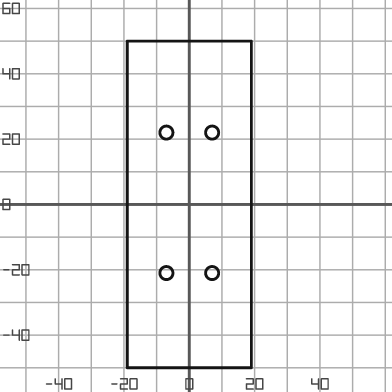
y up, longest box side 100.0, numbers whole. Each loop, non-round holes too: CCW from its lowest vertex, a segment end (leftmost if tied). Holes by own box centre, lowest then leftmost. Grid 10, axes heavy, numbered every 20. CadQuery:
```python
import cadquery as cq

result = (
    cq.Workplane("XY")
    .moveTo(-19.0, -50.0)
    .lineTo(19.0, -50.0)
    .lineTo(19.0, 50.0)
    .lineTo(-19.0, 50.0)
    .close()
    .moveTo(-7.0, -21.0)
    .circle(2.0)
    .moveTo(7.0, -21.0)
    .circle(2.0)
    .moveTo(-7.0, 22.0)
    .circle(2.0)
    .moveTo(7.0, 22.0)
    .circle(2.0)
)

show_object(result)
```